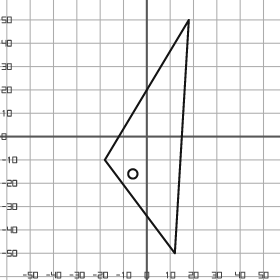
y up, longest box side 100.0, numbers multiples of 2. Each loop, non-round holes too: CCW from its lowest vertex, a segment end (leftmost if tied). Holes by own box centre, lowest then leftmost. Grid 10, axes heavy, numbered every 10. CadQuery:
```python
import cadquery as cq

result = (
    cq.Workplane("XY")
    .moveTo(12.0, -50.0)
    .lineTo(18.0, 50.0)
    .lineTo(-18.0, -10.0)
    .close()
    .moveTo(-6.0, -16.0)
    .circle(2.0)
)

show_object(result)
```